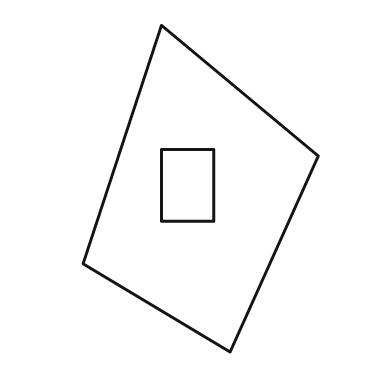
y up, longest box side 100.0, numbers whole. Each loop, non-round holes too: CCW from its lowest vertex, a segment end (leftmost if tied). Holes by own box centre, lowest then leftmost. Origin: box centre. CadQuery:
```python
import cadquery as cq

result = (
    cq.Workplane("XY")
    .moveTo(9.0, -50.0)
    .lineTo(36.0, 10.0)
    .lineTo(-12.0, 50.0)
    .lineTo(-36.0, -23.0)
    .close()
    .moveTo(-12.0, -10.0)
    .lineTo(4.0, -10.0)
    .lineTo(4.0, 12.0)
    .lineTo(-12.0, 12.0)
    .close()
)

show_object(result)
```